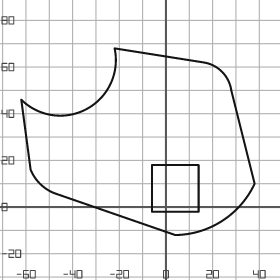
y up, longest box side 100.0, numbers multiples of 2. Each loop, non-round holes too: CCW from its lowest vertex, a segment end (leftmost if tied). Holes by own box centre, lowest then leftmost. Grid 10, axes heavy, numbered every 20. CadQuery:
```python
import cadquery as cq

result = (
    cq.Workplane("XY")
    .moveTo(4.0, -12.0)
    .threePointArc((24.0, -6.0), (38.0, 10.0))
    .lineTo(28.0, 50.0)
    .threePointArc((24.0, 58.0), (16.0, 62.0))
    .lineTo(-22.0, 68.0)
    .threePointArc((-34.0, 42.0), (-62.0, 46.0))
    .lineTo(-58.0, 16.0)
    .threePointArc((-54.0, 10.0), (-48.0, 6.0))
    .close()
    .moveTo(-6.0, -2.0)
    .lineTo(14.0, -2.0)
    .lineTo(14.0, 18.0)
    .lineTo(-6.0, 18.0)
    .close()
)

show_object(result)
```